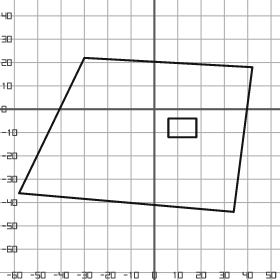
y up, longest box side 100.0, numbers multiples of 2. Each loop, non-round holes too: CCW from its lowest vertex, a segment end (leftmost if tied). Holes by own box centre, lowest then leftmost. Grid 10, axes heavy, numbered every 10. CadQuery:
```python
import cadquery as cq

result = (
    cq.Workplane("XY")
    .moveTo(34.0, -44.0)
    .lineTo(42.0, 18.0)
    .lineTo(-30.0, 22.0)
    .lineTo(-58.0, -36.0)
    .close()
    .moveTo(6.0, -12.0)
    .lineTo(18.0, -12.0)
    .lineTo(18.0, -4.0)
    .lineTo(6.0, -4.0)
    .close()
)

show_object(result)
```